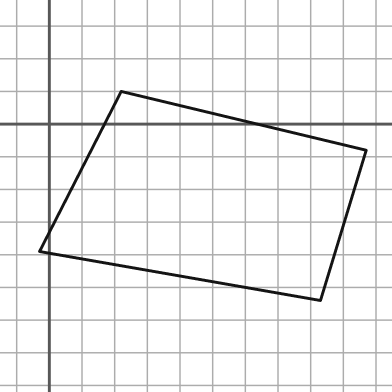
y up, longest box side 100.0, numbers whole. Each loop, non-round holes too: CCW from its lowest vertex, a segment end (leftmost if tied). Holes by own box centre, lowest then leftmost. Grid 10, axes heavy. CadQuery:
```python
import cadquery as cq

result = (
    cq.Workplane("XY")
    .moveTo(83.0, -54.0)
    .lineTo(97.0, -8.0)
    .lineTo(22.0, 10.0)
    .lineTo(-3.0, -39.0)
    .close()
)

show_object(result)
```